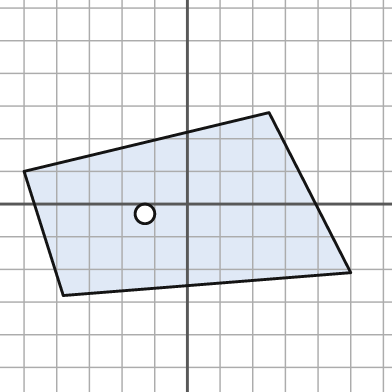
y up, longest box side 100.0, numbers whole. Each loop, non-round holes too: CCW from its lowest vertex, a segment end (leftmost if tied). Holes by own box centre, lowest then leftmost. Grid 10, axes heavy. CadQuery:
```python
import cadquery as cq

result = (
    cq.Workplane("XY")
    .moveTo(-38.0, -28.0)
    .lineTo(50.0, -21.0)
    .lineTo(25.0, 28.0)
    .lineTo(-50.0, 10.0)
    .close()
    .moveTo(-13.0, -3.0)
    .circle(3.0)
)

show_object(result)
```